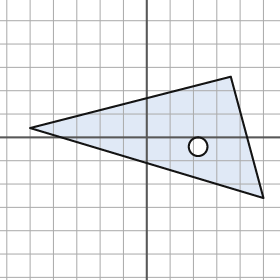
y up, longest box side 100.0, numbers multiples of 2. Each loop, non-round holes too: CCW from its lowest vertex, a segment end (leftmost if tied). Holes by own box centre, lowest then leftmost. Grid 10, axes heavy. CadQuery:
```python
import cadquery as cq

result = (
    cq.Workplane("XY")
    .moveTo(50.0, -26.0)
    .lineTo(36.0, 26.0)
    .lineTo(-50.0, 4.0)
    .close()
    .moveTo(22.0, -4.0)
    .circle(4.0)
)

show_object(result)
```